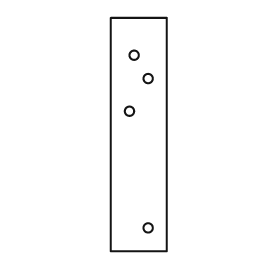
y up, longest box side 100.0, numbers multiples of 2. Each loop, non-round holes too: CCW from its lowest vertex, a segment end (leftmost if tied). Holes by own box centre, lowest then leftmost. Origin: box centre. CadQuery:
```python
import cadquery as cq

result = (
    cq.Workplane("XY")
    .moveTo(-12.0, -50.0)
    .lineTo(12.0, -50.0)
    .lineTo(12.0, 50.0)
    .lineTo(-12.0, 50.0)
    .close()
    .moveTo(4.0, -40.0)
    .circle(2.0)
    .moveTo(-4.0, 10.0)
    .circle(2.0)
    .moveTo(4.0, 24.0)
    .circle(2.0)
    .moveTo(-2.0, 34.0)
    .circle(2.0)
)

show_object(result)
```